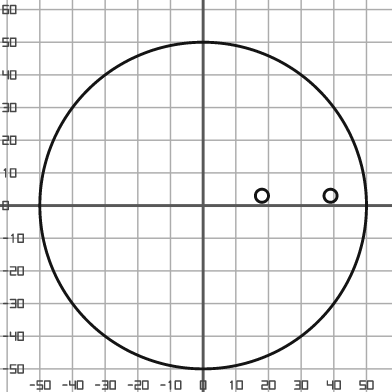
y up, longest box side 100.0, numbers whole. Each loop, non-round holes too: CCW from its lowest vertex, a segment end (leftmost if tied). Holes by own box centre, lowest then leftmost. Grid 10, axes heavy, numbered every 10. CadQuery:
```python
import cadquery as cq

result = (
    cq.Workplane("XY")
    .moveTo(0.0, 0.0)
    .circle(50.0)
    .moveTo(18.0, 3.0)
    .circle(2.0)
    .moveTo(39.0, 3.0)
    .circle(2.0)
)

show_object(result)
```